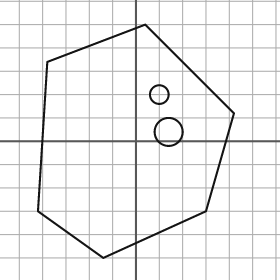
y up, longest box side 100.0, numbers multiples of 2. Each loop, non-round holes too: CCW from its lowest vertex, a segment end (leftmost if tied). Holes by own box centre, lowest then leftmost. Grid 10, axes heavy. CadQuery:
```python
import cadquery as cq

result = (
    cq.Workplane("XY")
    .moveTo(-14.0, -50.0)
    .lineTo(30.0, -30.0)
    .lineTo(42.0, 12.0)
    .lineTo(4.0, 50.0)
    .lineTo(-38.0, 34.0)
    .lineTo(-42.0, -30.0)
    .close()
    .moveTo(14.0, 4.0)
    .circle(6.0)
    .moveTo(10.0, 20.0)
    .circle(4.0)
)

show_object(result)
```